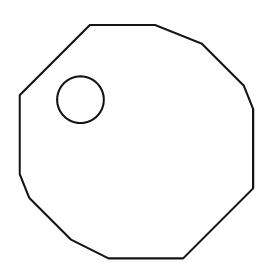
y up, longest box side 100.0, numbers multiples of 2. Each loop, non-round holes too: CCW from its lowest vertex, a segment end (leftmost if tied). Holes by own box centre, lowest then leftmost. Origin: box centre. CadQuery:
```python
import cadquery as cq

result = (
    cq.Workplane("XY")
    .moveTo(-12.0, -50.0)
    .lineTo(20.0, -50.0)
    .lineTo(50.0, -20.0)
    .lineTo(50.0, 14.0)
    .lineTo(46.0, 24.0)
    .lineTo(28.0, 42.0)
    .lineTo(8.0, 50.0)
    .lineTo(-20.0, 50.0)
    .lineTo(-50.0, 20.0)
    .lineTo(-50.0, -14.0)
    .lineTo(-46.0, -24.0)
    .lineTo(-28.0, -42.0)
    .close()
    .moveTo(-24.0, 18.0)
    .circle(10.0)
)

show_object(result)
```